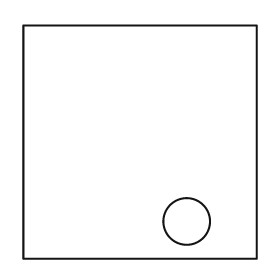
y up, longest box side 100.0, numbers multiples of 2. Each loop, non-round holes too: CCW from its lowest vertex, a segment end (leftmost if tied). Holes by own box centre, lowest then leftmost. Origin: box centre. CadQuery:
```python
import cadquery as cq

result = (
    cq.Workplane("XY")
    .moveTo(-50.0, -50.0)
    .lineTo(50.0, -50.0)
    .lineTo(50.0, 50.0)
    .lineTo(-50.0, 50.0)
    .close()
    .moveTo(20.0, -34.0)
    .circle(10.0)
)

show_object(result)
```